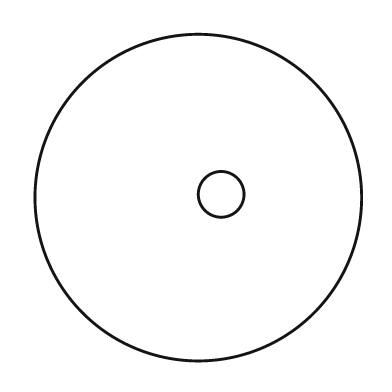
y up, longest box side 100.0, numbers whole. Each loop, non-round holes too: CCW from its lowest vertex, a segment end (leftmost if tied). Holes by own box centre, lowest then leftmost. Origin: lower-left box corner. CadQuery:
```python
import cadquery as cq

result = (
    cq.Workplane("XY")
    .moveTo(50.0, 50.0)
    .circle(50.0)
    .moveTo(57.0, 51.0)
    .circle(7.0)
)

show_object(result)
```